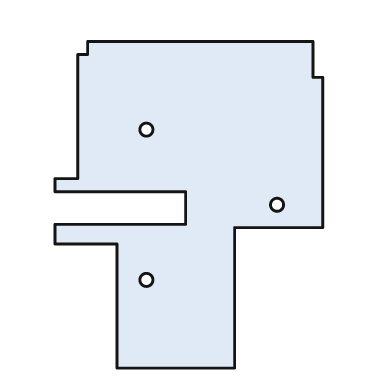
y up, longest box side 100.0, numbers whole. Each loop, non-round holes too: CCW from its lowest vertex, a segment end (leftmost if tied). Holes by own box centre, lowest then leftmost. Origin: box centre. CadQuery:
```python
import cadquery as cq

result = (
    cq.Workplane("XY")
    .moveTo(-22.0, -50.0)
    .lineTo(14.0, -50.0)
    .lineTo(14.0, -7.0)
    .lineTo(41.0, -7.0)
    .lineTo(41.0, 39.0)
    .lineTo(38.0, 39.0)
    .lineTo(38.0, 50.0)
    .lineTo(-31.0, 50.0)
    .lineTo(-31.0, 46.0)
    .lineTo(-34.0, 46.0)
    .lineTo(-34.0, 8.0)
    .lineTo(-41.0, 8.0)
    .lineTo(-41.0, 4.0)
    .lineTo(-1.0, 4.0)
    .lineTo(-1.0, -6.0)
    .lineTo(-41.0, -6.0)
    .lineTo(-41.0, -12.0)
    .lineTo(-22.0, -12.0)
    .close()
    .moveTo(-13.0, -23.0)
    .circle(2.0)
    .moveTo(27.0, 0.0)
    .circle(2.0)
    .moveTo(-13.0, 23.0)
    .circle(2.0)
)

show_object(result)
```